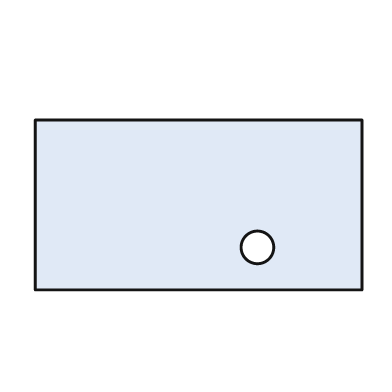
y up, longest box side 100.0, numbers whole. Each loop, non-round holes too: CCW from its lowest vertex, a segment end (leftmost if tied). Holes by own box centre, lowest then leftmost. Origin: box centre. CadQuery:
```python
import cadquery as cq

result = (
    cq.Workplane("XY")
    .moveTo(-50.0, -26.0)
    .lineTo(50.0, -26.0)
    .lineTo(50.0, 26.0)
    .lineTo(-50.0, 26.0)
    .close()
    .moveTo(18.0, -13.0)
    .circle(5.0)
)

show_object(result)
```